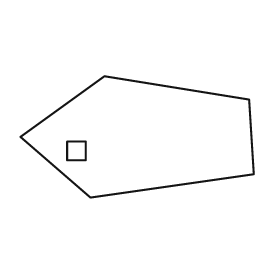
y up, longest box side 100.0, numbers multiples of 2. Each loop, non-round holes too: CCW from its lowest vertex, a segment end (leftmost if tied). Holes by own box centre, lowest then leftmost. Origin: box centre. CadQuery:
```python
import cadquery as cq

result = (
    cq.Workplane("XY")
    .moveTo(-20.0, -26.0)
    .lineTo(50.0, -16.0)
    .lineTo(48.0, 16.0)
    .lineTo(-14.0, 26.0)
    .lineTo(-50.0, 0.0)
    .close()
    .moveTo(-30.0, -10.0)
    .lineTo(-22.0, -10.0)
    .lineTo(-22.0, -2.0)
    .lineTo(-30.0, -2.0)
    .close()
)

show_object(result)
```